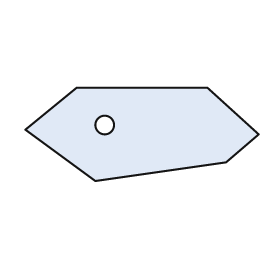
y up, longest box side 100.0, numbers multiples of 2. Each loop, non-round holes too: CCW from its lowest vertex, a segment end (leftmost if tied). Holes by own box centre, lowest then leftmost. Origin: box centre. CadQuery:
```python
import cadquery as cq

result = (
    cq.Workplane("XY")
    .moveTo(-20.0, -20.0)
    .lineTo(36.0, -12.0)
    .lineTo(50.0, 0.0)
    .lineTo(28.0, 20.0)
    .lineTo(-28.0, 20.0)
    .lineTo(-50.0, 2.0)
    .close()
    .moveTo(-16.0, 4.0)
    .circle(4.0)
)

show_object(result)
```